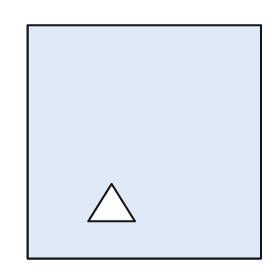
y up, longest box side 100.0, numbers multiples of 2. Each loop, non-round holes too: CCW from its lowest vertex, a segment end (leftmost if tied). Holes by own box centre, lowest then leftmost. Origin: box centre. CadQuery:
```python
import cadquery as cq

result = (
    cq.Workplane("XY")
    .moveTo(-50.0, -50.0)
    .lineTo(50.0, -50.0)
    .lineTo(50.0, 50.0)
    .lineTo(-50.0, 50.0)
    .close()
    .moveTo(-24.0, -34.0)
    .lineTo(-4.0, -34.0)
    .lineTo(-14.0, -18.0)
    .close()
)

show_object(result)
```